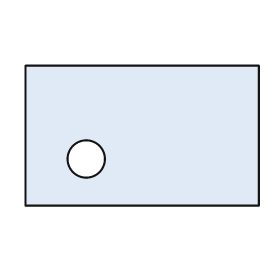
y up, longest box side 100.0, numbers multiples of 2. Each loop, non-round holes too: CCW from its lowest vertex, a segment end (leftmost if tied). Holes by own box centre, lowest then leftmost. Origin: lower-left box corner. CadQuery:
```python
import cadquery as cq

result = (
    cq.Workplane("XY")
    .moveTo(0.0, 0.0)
    .lineTo(100.0, 0.0)
    .lineTo(100.0, 60.0)
    .lineTo(0.0, 60.0)
    .close()
    .moveTo(26.0, 20.0)
    .circle(8.0)
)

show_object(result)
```